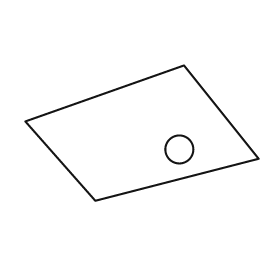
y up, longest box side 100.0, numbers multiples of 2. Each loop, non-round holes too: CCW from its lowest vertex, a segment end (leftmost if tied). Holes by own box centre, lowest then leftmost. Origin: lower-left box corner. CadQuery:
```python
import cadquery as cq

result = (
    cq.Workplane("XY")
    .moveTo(30.0, 0.0)
    .lineTo(100.0, 18.0)
    .lineTo(68.0, 58.0)
    .lineTo(0.0, 34.0)
    .close()
    .moveTo(66.0, 22.0)
    .circle(6.0)
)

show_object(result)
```